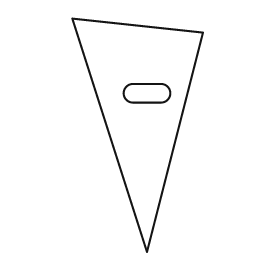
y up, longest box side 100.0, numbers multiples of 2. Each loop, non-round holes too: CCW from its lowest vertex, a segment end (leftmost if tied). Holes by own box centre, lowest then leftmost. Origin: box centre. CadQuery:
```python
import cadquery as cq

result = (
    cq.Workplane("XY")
    .moveTo(4.0, -50.0)
    .lineTo(28.0, 44.0)
    .lineTo(-28.0, 50.0)
    .close()
    .moveTo(-2.0, 14.0)
    .lineTo(10.0, 14.0)
    .threePointArc((14.0, 18.0), (10.0, 22.0))
    .lineTo(-2.0, 22.0)
    .threePointArc((-6.0, 18.0), (-2.0, 14.0))
    .close()
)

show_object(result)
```